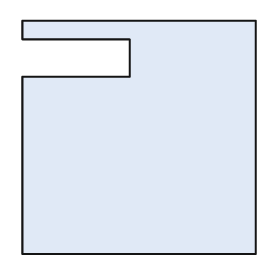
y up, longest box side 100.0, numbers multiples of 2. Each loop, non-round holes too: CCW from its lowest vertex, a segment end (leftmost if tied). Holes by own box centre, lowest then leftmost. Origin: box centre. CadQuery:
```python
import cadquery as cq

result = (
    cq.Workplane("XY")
    .moveTo(-50.0, -50.0)
    .lineTo(50.0, -50.0)
    .lineTo(50.0, 50.0)
    .lineTo(-50.0, 50.0)
    .lineTo(-50.0, 42.0)
    .lineTo(-4.0, 42.0)
    .lineTo(-4.0, 26.0)
    .lineTo(-50.0, 26.0)
    .close()
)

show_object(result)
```